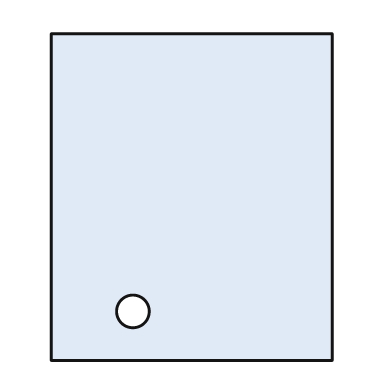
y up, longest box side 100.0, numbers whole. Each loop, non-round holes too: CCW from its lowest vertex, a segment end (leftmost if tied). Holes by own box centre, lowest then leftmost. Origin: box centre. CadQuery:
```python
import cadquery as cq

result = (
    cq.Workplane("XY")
    .moveTo(-43.0, -50.0)
    .lineTo(43.0, -50.0)
    .lineTo(43.0, 50.0)
    .lineTo(-43.0, 50.0)
    .close()
    .moveTo(-18.0, -35.0)
    .circle(5.0)
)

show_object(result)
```